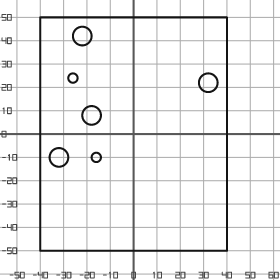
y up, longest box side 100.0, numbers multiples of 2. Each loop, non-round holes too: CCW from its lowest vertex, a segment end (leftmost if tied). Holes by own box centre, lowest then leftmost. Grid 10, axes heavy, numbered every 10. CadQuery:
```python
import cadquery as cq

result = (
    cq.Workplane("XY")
    .moveTo(-40.0, -50.0)
    .lineTo(40.0, -50.0)
    .lineTo(40.0, 50.0)
    .lineTo(-40.0, 50.0)
    .close()
    .moveTo(-32.0, -10.0)
    .circle(4.0)
    .moveTo(-16.0, -10.0)
    .circle(2.0)
    .moveTo(-18.0, 8.0)
    .circle(4.0)
    .moveTo(32.0, 22.0)
    .circle(4.0)
    .moveTo(-26.0, 24.0)
    .circle(2.0)
    .moveTo(-22.0, 42.0)
    .circle(4.0)
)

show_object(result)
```